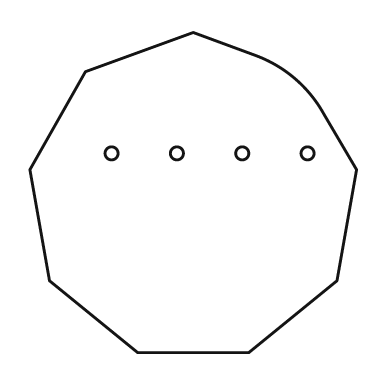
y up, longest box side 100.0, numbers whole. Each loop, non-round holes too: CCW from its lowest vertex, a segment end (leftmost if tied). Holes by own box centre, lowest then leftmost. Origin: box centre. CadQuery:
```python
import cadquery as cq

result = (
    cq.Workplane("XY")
    .moveTo(-17.0, -49.0)
    .lineTo(17.0, -49.0)
    .lineTo(44.0, -27.0)
    .lineTo(50.0, 7.0)
    .lineTo(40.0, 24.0)
    .threePointArc((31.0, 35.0), (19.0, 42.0))
    .lineTo(0.0, 49.0)
    .lineTo(-33.0, 37.0)
    .lineTo(-50.0, 7.0)
    .lineTo(-44.0, -27.0)
    .close()
    .moveTo(-25.0, 12.0)
    .circle(2.0)
    .moveTo(-5.0, 12.0)
    .circle(2.0)
    .moveTo(15.0, 12.0)
    .circle(2.0)
    .moveTo(35.0, 12.0)
    .circle(2.0)
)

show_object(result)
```